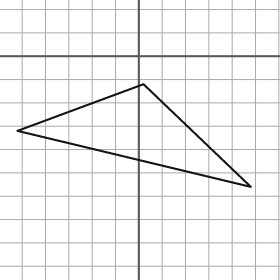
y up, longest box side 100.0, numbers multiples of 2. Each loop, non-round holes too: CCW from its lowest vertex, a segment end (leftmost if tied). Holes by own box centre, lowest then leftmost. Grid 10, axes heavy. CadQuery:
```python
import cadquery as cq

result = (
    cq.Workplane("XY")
    .moveTo(48.0, -56.0)
    .lineTo(2.0, -12.0)
    .lineTo(-52.0, -32.0)
    .close()
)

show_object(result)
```